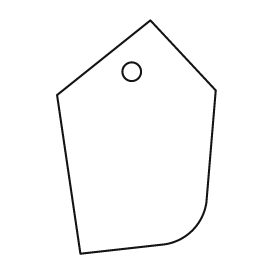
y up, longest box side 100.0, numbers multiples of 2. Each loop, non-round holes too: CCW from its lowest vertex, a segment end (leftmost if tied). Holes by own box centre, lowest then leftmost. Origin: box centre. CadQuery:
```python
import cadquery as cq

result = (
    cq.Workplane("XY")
    .moveTo(-24.0, -50.0)
    .lineTo(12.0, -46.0)
    .threePointArc((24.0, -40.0), (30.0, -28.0))
    .lineTo(34.0, 20.0)
    .lineTo(6.0, 50.0)
    .lineTo(-34.0, 18.0)
    .close()
    .moveTo(-2.0, 28.0)
    .circle(4.0)
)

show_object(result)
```